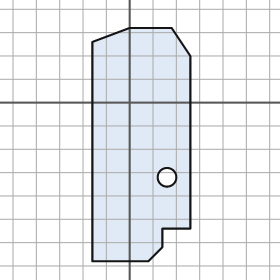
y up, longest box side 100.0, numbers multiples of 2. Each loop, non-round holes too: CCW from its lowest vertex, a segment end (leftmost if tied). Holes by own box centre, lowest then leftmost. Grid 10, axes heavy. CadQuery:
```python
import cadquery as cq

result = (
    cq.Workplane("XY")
    .moveTo(-16.0, -68.0)
    .lineTo(8.0, -68.0)
    .lineTo(14.0, -62.0)
    .lineTo(14.0, -54.0)
    .lineTo(26.0, -54.0)
    .lineTo(26.0, 20.0)
    .lineTo(18.0, 32.0)
    .lineTo(0.0, 32.0)
    .lineTo(-16.0, 26.0)
    .close()
    .moveTo(16.0, -32.0)
    .circle(4.0)
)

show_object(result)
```